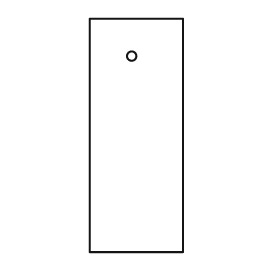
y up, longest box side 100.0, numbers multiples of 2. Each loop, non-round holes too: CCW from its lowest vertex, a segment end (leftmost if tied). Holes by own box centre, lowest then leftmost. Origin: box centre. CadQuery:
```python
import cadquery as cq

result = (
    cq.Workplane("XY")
    .moveTo(-20.0, -50.0)
    .lineTo(20.0, -50.0)
    .lineTo(20.0, 50.0)
    .lineTo(-20.0, 50.0)
    .close()
    .moveTo(-2.0, 34.0)
    .circle(2.0)
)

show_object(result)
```